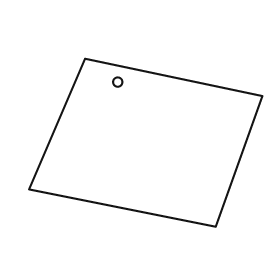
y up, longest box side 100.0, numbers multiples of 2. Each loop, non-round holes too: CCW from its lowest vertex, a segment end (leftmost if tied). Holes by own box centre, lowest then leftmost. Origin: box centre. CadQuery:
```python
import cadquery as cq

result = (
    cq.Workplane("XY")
    .moveTo(30.0, -36.0)
    .lineTo(50.0, 20.0)
    .lineTo(-26.0, 36.0)
    .lineTo(-50.0, -20.0)
    .close()
    .moveTo(-12.0, 26.0)
    .circle(2.0)
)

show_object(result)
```